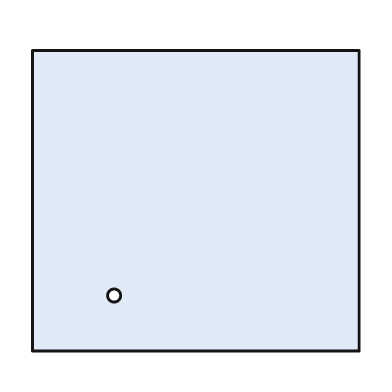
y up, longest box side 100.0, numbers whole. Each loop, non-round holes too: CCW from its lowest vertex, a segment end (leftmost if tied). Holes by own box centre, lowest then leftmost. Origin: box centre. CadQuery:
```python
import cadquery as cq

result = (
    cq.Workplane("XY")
    .moveTo(-50.0, -46.0)
    .lineTo(50.0, -46.0)
    .lineTo(50.0, 46.0)
    .lineTo(-50.0, 46.0)
    .close()
    .moveTo(-25.0, -29.0)
    .circle(2.0)
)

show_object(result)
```